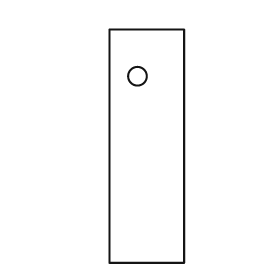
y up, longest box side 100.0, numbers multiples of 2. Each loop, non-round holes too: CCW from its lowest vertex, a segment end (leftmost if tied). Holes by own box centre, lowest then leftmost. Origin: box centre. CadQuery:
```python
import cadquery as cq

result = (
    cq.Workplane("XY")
    .moveTo(-16.0, -50.0)
    .lineTo(16.0, -50.0)
    .lineTo(16.0, 50.0)
    .lineTo(-16.0, 50.0)
    .close()
    .moveTo(-4.0, 30.0)
    .circle(4.0)
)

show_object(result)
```